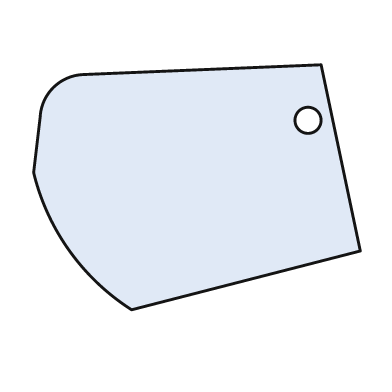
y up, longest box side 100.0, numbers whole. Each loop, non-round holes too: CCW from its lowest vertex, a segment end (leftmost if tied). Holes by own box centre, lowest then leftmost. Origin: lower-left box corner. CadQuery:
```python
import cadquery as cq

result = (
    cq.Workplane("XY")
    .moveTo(30.0, 0.0)
    .lineTo(100.0, 18.0)
    .lineTo(88.0, 75.0)
    .lineTo(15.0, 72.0)
    .threePointArc((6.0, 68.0), (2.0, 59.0))
    .lineTo(0.0, 42.0)
    .threePointArc((11.0, 18.0), (30.0, 0.0))
    .close()
    .moveTo(84.0, 58.0)
    .circle(4.0)
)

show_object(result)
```